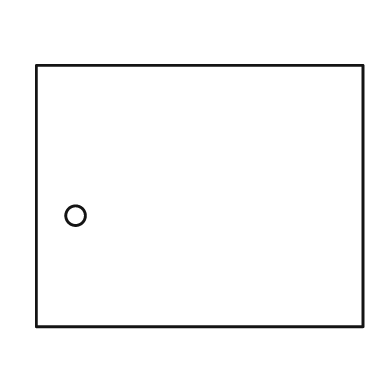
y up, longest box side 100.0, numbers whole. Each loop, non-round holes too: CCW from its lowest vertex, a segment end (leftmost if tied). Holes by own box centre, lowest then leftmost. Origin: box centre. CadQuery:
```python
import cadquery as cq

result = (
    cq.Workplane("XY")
    .moveTo(-50.0, -40.0)
    .lineTo(50.0, -40.0)
    .lineTo(50.0, 40.0)
    .lineTo(-50.0, 40.0)
    .close()
    .moveTo(-38.0, -6.0)
    .circle(3.0)
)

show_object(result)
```